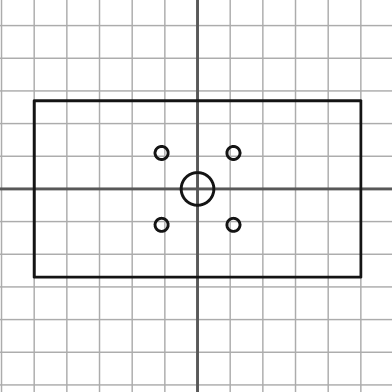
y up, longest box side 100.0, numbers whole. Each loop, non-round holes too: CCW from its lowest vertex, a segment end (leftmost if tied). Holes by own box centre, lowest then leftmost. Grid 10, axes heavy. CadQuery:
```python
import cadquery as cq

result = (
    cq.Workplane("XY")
    .moveTo(-50.0, -27.0)
    .lineTo(50.0, -27.0)
    .lineTo(50.0, 27.0)
    .lineTo(-50.0, 27.0)
    .close()
    .moveTo(-11.0, -11.0)
    .circle(2.0)
    .moveTo(11.0, -11.0)
    .circle(2.0)
    .moveTo(0.0, 0.0)
    .circle(5.0)
    .moveTo(-11.0, 11.0)
    .circle(2.0)
    .moveTo(11.0, 11.0)
    .circle(2.0)
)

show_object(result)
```